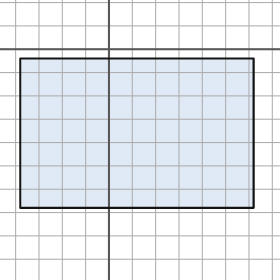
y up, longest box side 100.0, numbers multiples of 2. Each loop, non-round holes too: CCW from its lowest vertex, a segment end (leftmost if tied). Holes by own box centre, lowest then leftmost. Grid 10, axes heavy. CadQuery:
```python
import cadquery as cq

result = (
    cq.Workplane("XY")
    .moveTo(-38.0, -68.0)
    .lineTo(62.0, -68.0)
    .lineTo(62.0, -4.0)
    .lineTo(-38.0, -4.0)
    .close()
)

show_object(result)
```